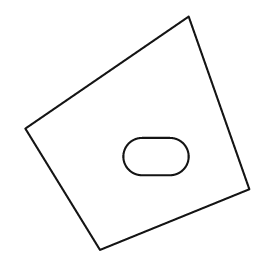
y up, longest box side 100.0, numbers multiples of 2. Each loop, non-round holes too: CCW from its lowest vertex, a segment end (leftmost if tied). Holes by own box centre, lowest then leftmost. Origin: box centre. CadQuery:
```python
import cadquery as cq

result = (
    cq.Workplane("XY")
    .moveTo(-16.0, -50.0)
    .lineTo(48.0, -24.0)
    .lineTo(22.0, 50.0)
    .lineTo(-48.0, 2.0)
    .close()
    .moveTo(2.0, -18.0)
    .lineTo(14.0, -18.0)
    .threePointArc((22.0, -10.0), (14.0, -2.0))
    .lineTo(2.0, -2.0)
    .threePointArc((-6.0, -10.0), (2.0, -18.0))
    .close()
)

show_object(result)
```